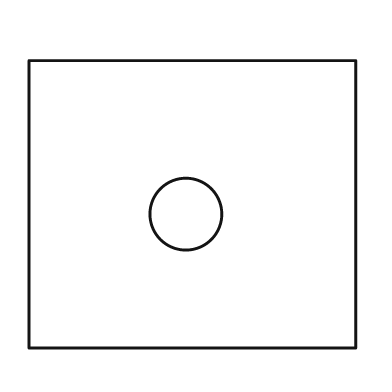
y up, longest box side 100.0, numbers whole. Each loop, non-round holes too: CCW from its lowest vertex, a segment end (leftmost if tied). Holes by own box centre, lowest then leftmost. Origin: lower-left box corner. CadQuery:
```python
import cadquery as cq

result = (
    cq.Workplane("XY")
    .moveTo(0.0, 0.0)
    .lineTo(100.0, 0.0)
    .lineTo(100.0, 88.0)
    .lineTo(0.0, 88.0)
    .close()
    .moveTo(48.0, 41.0)
    .circle(11.0)
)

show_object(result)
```